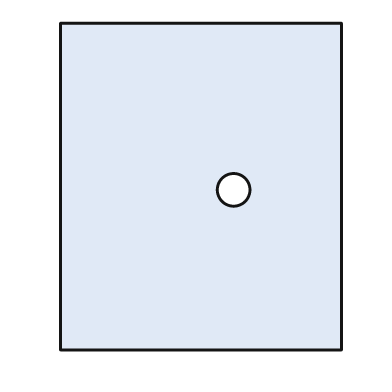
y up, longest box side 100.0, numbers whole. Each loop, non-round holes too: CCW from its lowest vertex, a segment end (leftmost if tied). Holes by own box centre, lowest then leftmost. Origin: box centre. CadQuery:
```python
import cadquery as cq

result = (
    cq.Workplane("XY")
    .moveTo(-43.0, -50.0)
    .lineTo(43.0, -50.0)
    .lineTo(43.0, 50.0)
    .lineTo(-43.0, 50.0)
    .close()
    .moveTo(10.0, -1.0)
    .circle(5.0)
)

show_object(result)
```